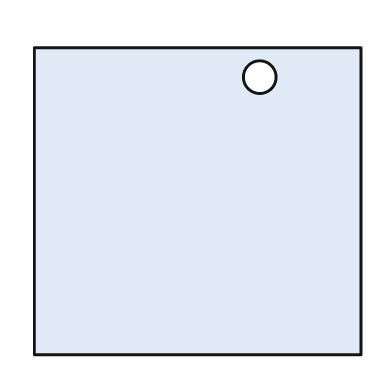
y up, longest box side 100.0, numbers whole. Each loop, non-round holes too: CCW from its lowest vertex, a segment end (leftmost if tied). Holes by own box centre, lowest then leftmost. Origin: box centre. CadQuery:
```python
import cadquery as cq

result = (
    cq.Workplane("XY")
    .moveTo(-50.0, -47.0)
    .lineTo(50.0, -47.0)
    .lineTo(50.0, 47.0)
    .lineTo(-50.0, 47.0)
    .close()
    .moveTo(19.0, 38.0)
    .circle(5.0)
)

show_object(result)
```